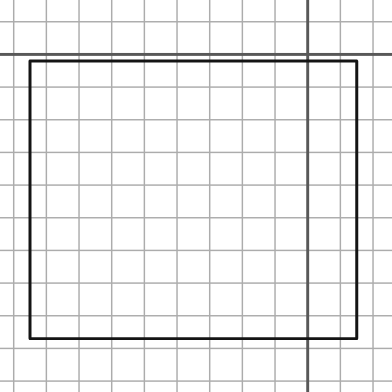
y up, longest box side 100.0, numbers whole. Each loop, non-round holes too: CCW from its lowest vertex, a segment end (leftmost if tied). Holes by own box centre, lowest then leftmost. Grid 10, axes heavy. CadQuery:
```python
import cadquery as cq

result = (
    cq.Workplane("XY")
    .moveTo(-85.0, -87.0)
    .lineTo(15.0, -87.0)
    .lineTo(15.0, -2.0)
    .lineTo(-85.0, -2.0)
    .close()
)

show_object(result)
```